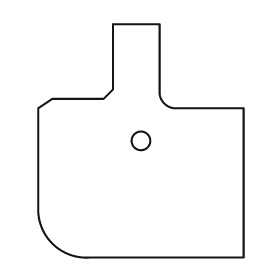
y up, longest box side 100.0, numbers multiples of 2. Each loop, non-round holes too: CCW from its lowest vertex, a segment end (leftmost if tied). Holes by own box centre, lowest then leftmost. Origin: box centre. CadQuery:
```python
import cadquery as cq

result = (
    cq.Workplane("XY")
    .moveTo(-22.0, -50.0)
    .lineTo(44.0, -50.0)
    .lineTo(44.0, 14.0)
    .lineTo(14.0, 14.0)
    .threePointArc((10.0, 16.0), (8.0, 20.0))
    .lineTo(8.0, 50.0)
    .lineTo(-12.0, 50.0)
    .lineTo(-12.0, 22.0)
    .lineTo(-16.0, 18.0)
    .lineTo(-38.0, 18.0)
    .lineTo(-44.0, 14.0)
    .lineTo(-44.0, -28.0)
    .threePointArc((-38.0, -44.0), (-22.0, -50.0))
    .close()
    .moveTo(0.0, 0.0)
    .circle(4.0)
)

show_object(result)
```